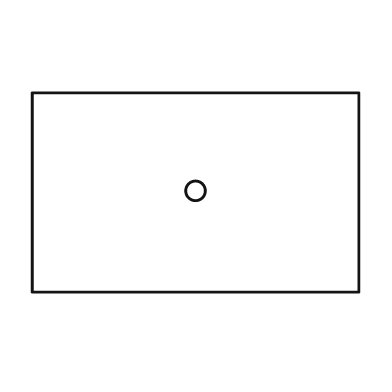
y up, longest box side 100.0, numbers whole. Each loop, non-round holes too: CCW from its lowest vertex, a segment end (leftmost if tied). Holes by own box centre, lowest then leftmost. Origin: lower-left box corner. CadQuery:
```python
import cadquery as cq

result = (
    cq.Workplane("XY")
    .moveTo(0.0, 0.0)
    .lineTo(100.0, 0.0)
    .lineTo(100.0, 61.0)
    .lineTo(0.0, 61.0)
    .close()
    .moveTo(50.0, 31.0)
    .circle(3.0)
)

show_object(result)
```